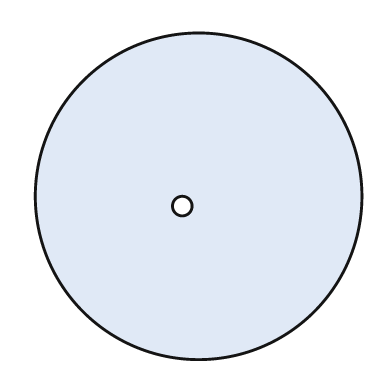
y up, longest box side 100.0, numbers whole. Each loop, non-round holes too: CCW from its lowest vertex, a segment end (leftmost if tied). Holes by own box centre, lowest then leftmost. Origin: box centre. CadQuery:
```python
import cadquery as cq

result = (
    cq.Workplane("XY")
    .moveTo(0.0, 0.0)
    .circle(50.0)
    .moveTo(-5.0, -3.0)
    .circle(3.0)
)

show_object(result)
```